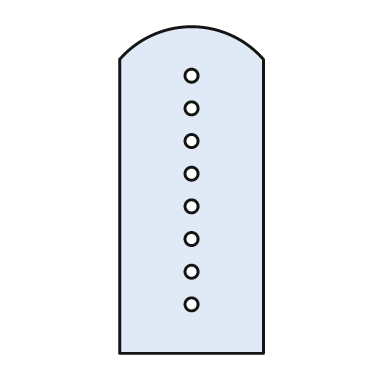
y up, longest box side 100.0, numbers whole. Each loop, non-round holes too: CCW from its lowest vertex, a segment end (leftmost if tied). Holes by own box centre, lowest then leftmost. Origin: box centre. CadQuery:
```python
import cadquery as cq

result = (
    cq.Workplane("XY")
    .moveTo(-22.0, -50.0)
    .lineTo(22.0, -50.0)
    .lineTo(22.0, 40.0)
    .threePointArc((0.0, 50.0), (-22.0, 40.0))
    .close()
    .moveTo(0.0, -35.0)
    .circle(2.0)
    .moveTo(0.0, -25.0)
    .circle(2.0)
    .moveTo(0.0, -15.0)
    .circle(2.0)
    .moveTo(0.0, -5.0)
    .circle(2.0)
    .moveTo(0.0, 5.0)
    .circle(2.0)
    .moveTo(0.0, 15.0)
    .circle(2.0)
    .moveTo(0.0, 25.0)
    .circle(2.0)
    .moveTo(0.0, 35.0)
    .circle(2.0)
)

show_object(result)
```